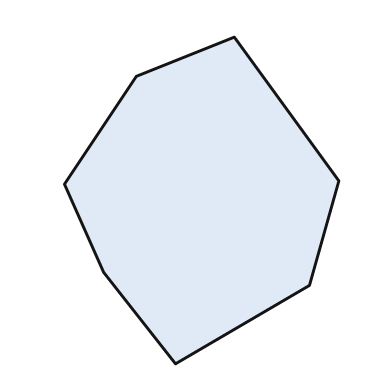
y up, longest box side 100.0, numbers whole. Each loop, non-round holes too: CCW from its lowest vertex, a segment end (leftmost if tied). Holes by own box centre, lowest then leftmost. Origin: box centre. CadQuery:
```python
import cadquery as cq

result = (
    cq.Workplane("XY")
    .moveTo(-8.0, -50.0)
    .lineTo(33.0, -26.0)
    .lineTo(42.0, 6.0)
    .lineTo(10.0, 50.0)
    .lineTo(-20.0, 38.0)
    .lineTo(-42.0, 5.0)
    .lineTo(-30.0, -22.0)
    .close()
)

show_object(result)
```